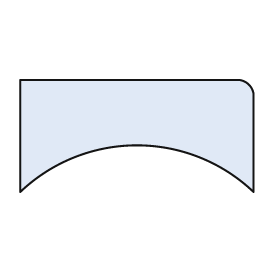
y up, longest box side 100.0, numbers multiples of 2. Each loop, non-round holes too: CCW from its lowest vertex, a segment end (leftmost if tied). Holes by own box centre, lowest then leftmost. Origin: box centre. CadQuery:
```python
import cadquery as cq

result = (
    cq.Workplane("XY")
    .moveTo(-50.0, -24.0)
    .threePointArc((0.0, -4.0), (50.0, -24.0))
    .lineTo(50.0, 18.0)
    .threePointArc((48.0, 22.0), (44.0, 24.0))
    .lineTo(-50.0, 24.0)
    .close()
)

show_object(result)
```